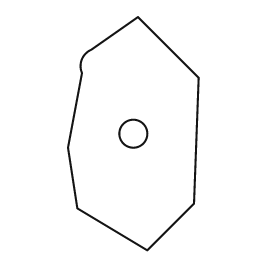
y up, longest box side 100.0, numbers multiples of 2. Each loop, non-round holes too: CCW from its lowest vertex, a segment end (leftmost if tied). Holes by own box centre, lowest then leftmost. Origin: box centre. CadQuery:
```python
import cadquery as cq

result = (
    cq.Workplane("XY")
    .moveTo(6.0, -50.0)
    .lineTo(26.0, -30.0)
    .lineTo(28.0, 24.0)
    .lineTo(2.0, 50.0)
    .lineTo(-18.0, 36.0)
    .threePointArc((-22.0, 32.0), (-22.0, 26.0))
    .lineTo(-28.0, -6.0)
    .lineTo(-24.0, -32.0)
    .close()
    .moveTo(0.0, 0.0)
    .circle(6.0)
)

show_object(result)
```